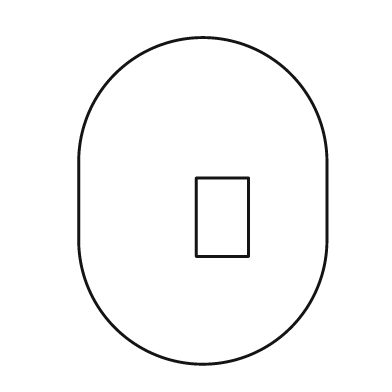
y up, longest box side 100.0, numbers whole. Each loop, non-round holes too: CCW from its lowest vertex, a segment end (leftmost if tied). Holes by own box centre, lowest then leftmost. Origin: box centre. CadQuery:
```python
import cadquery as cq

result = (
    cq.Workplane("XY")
    .moveTo(-38.0, -12.0)
    .threePointArc((0.0, -50.0), (38.0, -12.0))
    .lineTo(38.0, 12.0)
    .threePointArc((0.0, 50.0), (-38.0, 12.0))
    .close()
    .moveTo(-2.0, -17.0)
    .lineTo(14.0, -17.0)
    .lineTo(14.0, 7.0)
    .lineTo(-2.0, 7.0)
    .close()
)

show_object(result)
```